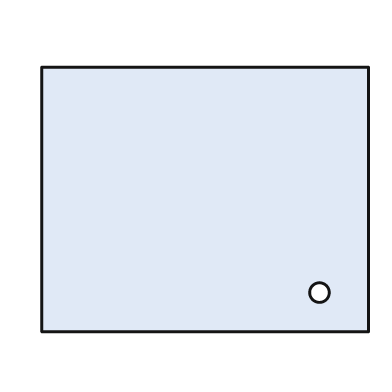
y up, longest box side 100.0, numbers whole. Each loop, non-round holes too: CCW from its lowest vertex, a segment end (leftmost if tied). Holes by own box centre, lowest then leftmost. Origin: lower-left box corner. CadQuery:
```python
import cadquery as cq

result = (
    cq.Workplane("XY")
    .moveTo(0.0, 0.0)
    .lineTo(100.0, 0.0)
    .lineTo(100.0, 81.0)
    .lineTo(0.0, 81.0)
    .close()
    .moveTo(85.0, 12.0)
    .circle(3.0)
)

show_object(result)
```